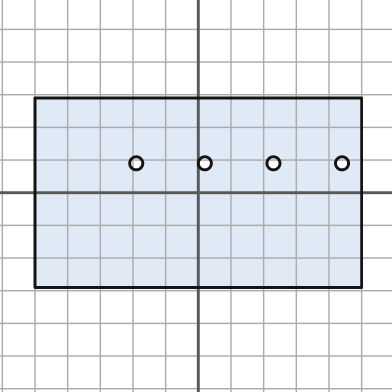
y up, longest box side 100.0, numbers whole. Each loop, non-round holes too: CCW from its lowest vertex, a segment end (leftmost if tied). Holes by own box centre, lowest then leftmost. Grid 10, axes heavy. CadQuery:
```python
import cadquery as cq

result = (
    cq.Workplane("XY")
    .moveTo(-50.0, -29.0)
    .lineTo(50.0, -29.0)
    .lineTo(50.0, 29.0)
    .lineTo(-50.0, 29.0)
    .close()
    .moveTo(-19.0, 9.0)
    .circle(2.0)
    .moveTo(2.0, 9.0)
    .circle(2.0)
    .moveTo(23.0, 9.0)
    .circle(2.0)
    .moveTo(44.0, 9.0)
    .circle(2.0)
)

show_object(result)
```